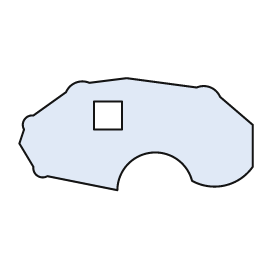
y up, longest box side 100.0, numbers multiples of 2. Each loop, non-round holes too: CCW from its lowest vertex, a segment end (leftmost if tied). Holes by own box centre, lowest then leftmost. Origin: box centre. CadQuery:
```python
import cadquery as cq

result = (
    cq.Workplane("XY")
    .moveTo(-8.0, -24.0)
    .threePointArc((6.0, -8.0), (24.0, -20.0))
    .threePointArc((38.0, -22.0), (50.0, -14.0))
    .lineTo(50.0, 4.0)
    .lineTo(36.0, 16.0)
    .threePointArc((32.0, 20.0), (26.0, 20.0))
    .lineTo(-4.0, 24.0)
    .lineTo(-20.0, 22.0)
    .threePointArc((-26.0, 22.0), (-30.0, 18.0))
    .lineTo(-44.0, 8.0)
    .threePointArc((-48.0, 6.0), (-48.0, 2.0))
    .lineTo(-50.0, -4.0)
    .lineTo(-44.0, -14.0)
    .threePointArc((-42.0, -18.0), (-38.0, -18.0))
    .close()
    .moveTo(-18.0, 2.0)
    .lineTo(-6.0, 2.0)
    .lineTo(-6.0, 14.0)
    .lineTo(-18.0, 14.0)
    .close()
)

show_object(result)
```